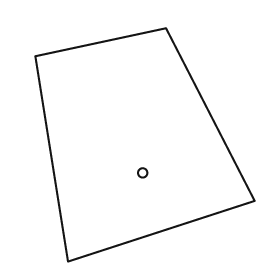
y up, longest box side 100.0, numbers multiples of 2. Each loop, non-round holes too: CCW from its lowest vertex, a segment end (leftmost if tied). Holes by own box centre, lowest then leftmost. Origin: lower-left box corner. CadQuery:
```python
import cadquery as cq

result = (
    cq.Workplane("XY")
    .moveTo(14.0, 0.0)
    .lineTo(94.0, 26.0)
    .lineTo(56.0, 100.0)
    .lineTo(0.0, 88.0)
    .close()
    .moveTo(46.0, 38.0)
    .circle(2.0)
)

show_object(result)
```